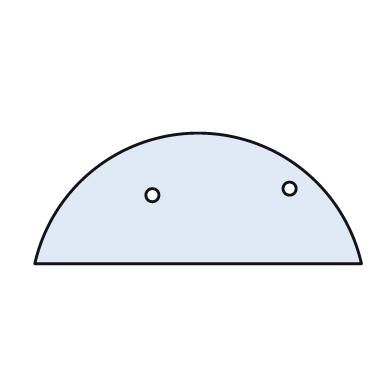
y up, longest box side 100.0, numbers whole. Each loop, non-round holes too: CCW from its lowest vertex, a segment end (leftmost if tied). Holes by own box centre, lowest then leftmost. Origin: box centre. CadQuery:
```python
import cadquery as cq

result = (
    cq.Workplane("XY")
    .moveTo(-50.0, -20.0)
    .lineTo(50.0, -20.0)
    .threePointArc((0.0, 20.0), (-50.0, -20.0))
    .close()
    .moveTo(-14.0, 1.0)
    .circle(2.0)
    .moveTo(28.0, 3.0)
    .circle(2.0)
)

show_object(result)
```